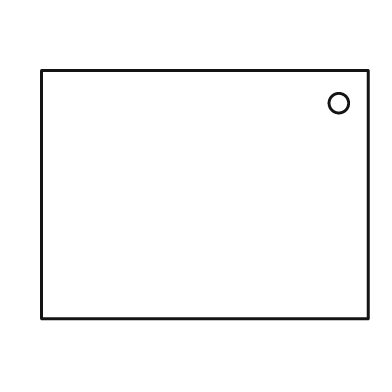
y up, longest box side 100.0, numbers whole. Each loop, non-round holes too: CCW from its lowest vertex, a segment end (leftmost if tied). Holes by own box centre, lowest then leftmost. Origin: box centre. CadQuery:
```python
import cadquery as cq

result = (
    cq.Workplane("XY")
    .moveTo(-50.0, -38.0)
    .lineTo(50.0, -38.0)
    .lineTo(50.0, 38.0)
    .lineTo(-50.0, 38.0)
    .close()
    .moveTo(41.0, 28.0)
    .circle(3.0)
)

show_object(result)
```